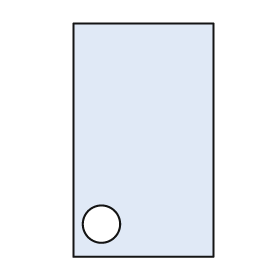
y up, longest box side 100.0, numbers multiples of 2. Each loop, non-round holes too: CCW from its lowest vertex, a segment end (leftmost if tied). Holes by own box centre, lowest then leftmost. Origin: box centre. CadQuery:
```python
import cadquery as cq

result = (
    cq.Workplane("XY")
    .moveTo(-30.0, -50.0)
    .lineTo(30.0, -50.0)
    .lineTo(30.0, 50.0)
    .lineTo(-30.0, 50.0)
    .close()
    .moveTo(-18.0, -36.0)
    .circle(8.0)
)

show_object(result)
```